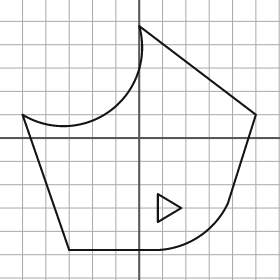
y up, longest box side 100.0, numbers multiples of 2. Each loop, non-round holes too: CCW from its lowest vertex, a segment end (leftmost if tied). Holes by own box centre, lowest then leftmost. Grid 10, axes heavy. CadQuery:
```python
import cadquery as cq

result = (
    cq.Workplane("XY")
    .moveTo(-30.0, -48.0)
    .lineTo(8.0, -48.0)
    .threePointArc((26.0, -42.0), (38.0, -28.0))
    .lineTo(50.0, 10.0)
    .lineTo(0.0, 48.0)
    .threePointArc((-12.0, 12.0), (-50.0, 10.0))
    .close()
    .moveTo(8.0, -36.0)
    .lineTo(18.0, -30.0)
    .lineTo(8.0, -24.0)
    .close()
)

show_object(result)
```